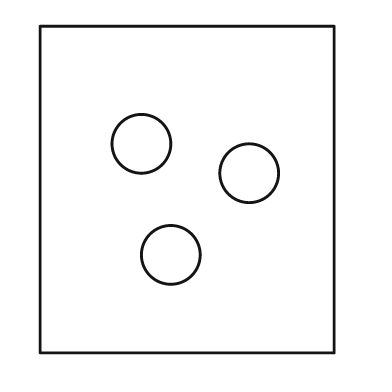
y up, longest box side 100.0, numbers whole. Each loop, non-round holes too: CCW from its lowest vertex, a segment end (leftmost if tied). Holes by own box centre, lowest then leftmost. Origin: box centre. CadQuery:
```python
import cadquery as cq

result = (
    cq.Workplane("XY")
    .moveTo(-45.0, -50.0)
    .lineTo(45.0, -50.0)
    .lineTo(45.0, 50.0)
    .lineTo(-45.0, 50.0)
    .close()
    .moveTo(-5.0, -20.0)
    .circle(9.0)
    .moveTo(19.0, 5.0)
    .circle(9.0)
    .moveTo(-14.0, 14.0)
    .circle(9.0)
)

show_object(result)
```